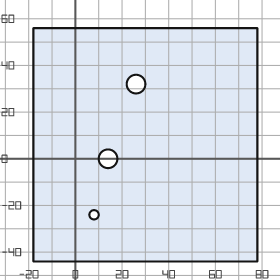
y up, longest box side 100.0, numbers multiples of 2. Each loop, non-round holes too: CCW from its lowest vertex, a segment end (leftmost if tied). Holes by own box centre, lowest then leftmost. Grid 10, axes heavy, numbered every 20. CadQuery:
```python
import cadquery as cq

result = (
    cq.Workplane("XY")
    .moveTo(-18.0, -44.0)
    .lineTo(78.0, -44.0)
    .lineTo(78.0, 56.0)
    .lineTo(-18.0, 56.0)
    .close()
    .moveTo(8.0, -24.0)
    .circle(2.0)
    .moveTo(14.0, 0.0)
    .circle(4.0)
    .moveTo(26.0, 32.0)
    .circle(4.0)
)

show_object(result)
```